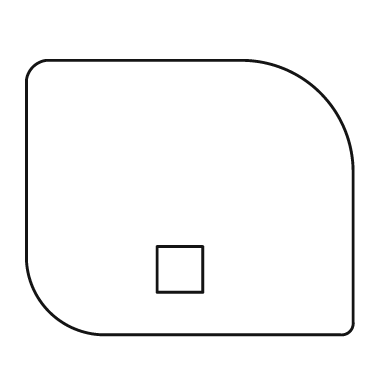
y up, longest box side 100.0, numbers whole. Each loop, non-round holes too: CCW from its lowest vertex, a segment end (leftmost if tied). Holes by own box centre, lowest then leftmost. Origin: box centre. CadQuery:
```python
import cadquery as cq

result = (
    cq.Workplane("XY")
    .moveTo(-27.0, -42.0)
    .lineTo(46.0, -42.0)
    .threePointArc((49.0, -41.0), (50.0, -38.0))
    .lineTo(50.0, 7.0)
    .threePointArc((40.0, 32.0), (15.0, 42.0))
    .lineTo(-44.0, 42.0)
    .threePointArc((-48.0, 40.0), (-50.0, 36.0))
    .lineTo(-50.0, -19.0)
    .threePointArc((-43.0, -35.0), (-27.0, -42.0))
    .close()
    .moveTo(-10.0, -29.0)
    .lineTo(4.0, -29.0)
    .lineTo(4.0, -15.0)
    .lineTo(-10.0, -15.0)
    .close()
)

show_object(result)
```